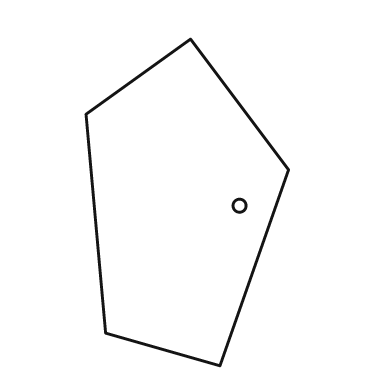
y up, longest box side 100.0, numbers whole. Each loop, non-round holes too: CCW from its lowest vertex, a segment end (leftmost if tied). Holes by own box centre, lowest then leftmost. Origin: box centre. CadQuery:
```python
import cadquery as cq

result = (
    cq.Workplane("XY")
    .moveTo(10.0, -50.0)
    .lineTo(31.0, 10.0)
    .lineTo(1.0, 50.0)
    .lineTo(-31.0, 27.0)
    .lineTo(-25.0, -40.0)
    .close()
    .moveTo(16.0, -1.0)
    .circle(2.0)
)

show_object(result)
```